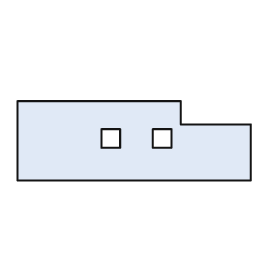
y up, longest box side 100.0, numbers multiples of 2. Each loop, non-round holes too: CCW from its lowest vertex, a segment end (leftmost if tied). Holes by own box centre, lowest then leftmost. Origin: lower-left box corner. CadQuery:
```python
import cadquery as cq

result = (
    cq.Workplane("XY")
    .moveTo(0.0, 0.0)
    .lineTo(100.0, 0.0)
    .lineTo(100.0, 24.0)
    .lineTo(70.0, 24.0)
    .lineTo(70.0, 34.0)
    .lineTo(0.0, 34.0)
    .close()
    .moveTo(36.0, 14.0)
    .lineTo(44.0, 14.0)
    .lineTo(44.0, 22.0)
    .lineTo(36.0, 22.0)
    .close()
    .moveTo(58.0, 14.0)
    .lineTo(66.0, 14.0)
    .lineTo(66.0, 22.0)
    .lineTo(58.0, 22.0)
    .close()
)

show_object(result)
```